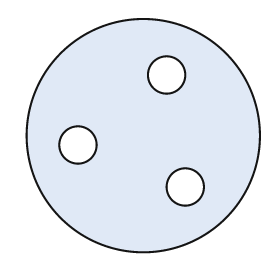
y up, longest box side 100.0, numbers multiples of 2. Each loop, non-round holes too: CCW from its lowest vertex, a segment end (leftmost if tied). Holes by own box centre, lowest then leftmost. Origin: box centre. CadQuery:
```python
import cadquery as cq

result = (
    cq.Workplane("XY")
    .moveTo(0.0, 0.0)
    .circle(50.0)
    .moveTo(18.0, -22.0)
    .circle(8.0)
    .moveTo(-28.0, -4.0)
    .circle(8.0)
    .moveTo(10.0, 26.0)
    .circle(8.0)
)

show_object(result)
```